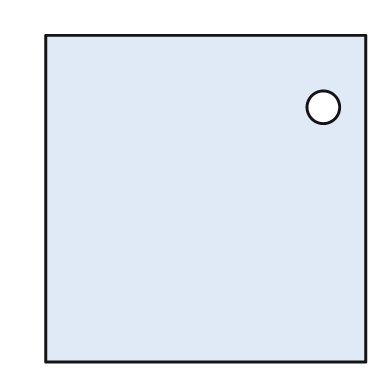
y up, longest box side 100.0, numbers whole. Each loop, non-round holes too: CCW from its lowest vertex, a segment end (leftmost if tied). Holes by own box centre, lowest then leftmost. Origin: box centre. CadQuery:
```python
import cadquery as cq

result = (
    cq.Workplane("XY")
    .moveTo(-49.0, -50.0)
    .lineTo(49.0, -50.0)
    .lineTo(49.0, 50.0)
    .lineTo(-49.0, 50.0)
    .close()
    .moveTo(36.0, 28.0)
    .circle(5.0)
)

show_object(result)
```